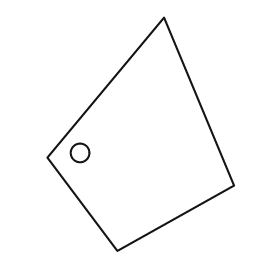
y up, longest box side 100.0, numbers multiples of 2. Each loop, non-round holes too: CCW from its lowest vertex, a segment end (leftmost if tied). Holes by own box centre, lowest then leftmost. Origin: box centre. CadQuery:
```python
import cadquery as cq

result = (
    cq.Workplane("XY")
    .moveTo(-10.0, -50.0)
    .lineTo(40.0, -22.0)
    .lineTo(10.0, 50.0)
    .lineTo(-40.0, -10.0)
    .close()
    .moveTo(-26.0, -8.0)
    .circle(4.0)
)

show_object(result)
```